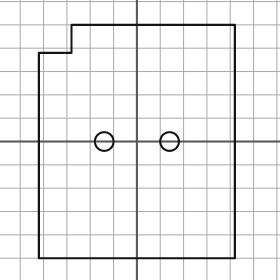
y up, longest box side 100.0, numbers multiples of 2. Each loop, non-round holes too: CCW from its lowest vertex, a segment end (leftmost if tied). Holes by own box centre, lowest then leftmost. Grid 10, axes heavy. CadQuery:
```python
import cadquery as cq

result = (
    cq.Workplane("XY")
    .moveTo(-42.0, -50.0)
    .lineTo(42.0, -50.0)
    .lineTo(42.0, 50.0)
    .lineTo(-28.0, 50.0)
    .lineTo(-28.0, 38.0)
    .lineTo(-42.0, 38.0)
    .close()
    .moveTo(-14.0, 0.0)
    .circle(4.0)
    .moveTo(14.0, 0.0)
    .circle(4.0)
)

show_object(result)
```